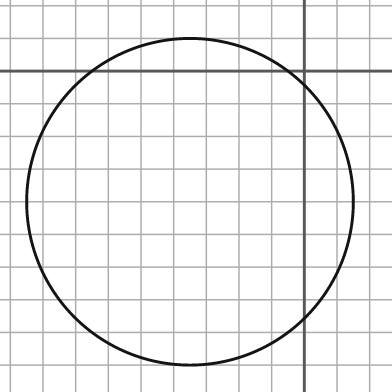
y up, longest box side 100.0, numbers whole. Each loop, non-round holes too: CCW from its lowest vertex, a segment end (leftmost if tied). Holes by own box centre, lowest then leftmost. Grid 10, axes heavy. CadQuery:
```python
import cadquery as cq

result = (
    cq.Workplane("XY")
    .moveTo(-35.0, -40.0)
    .circle(50.0)
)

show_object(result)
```